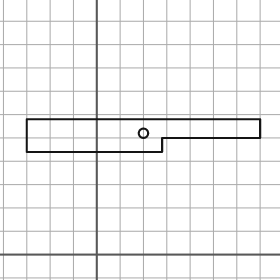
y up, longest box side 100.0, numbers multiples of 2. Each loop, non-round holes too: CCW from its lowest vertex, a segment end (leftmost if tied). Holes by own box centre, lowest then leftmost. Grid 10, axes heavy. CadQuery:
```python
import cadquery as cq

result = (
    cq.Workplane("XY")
    .moveTo(-30.0, 44.0)
    .lineTo(28.0, 44.0)
    .lineTo(28.0, 50.0)
    .lineTo(70.0, 50.0)
    .lineTo(70.0, 58.0)
    .lineTo(-30.0, 58.0)
    .close()
    .moveTo(20.0, 52.0)
    .circle(2.0)
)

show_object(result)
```